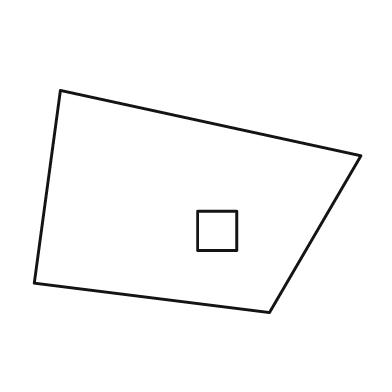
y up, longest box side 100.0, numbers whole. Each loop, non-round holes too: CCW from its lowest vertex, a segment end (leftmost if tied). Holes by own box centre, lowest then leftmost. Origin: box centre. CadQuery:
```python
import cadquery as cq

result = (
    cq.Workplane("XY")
    .moveTo(22.0, -34.0)
    .lineTo(50.0, 14.0)
    .lineTo(-42.0, 34.0)
    .lineTo(-50.0, -25.0)
    .close()
    .moveTo(0.0, -15.0)
    .lineTo(12.0, -15.0)
    .lineTo(12.0, -3.0)
    .lineTo(0.0, -3.0)
    .close()
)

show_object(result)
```